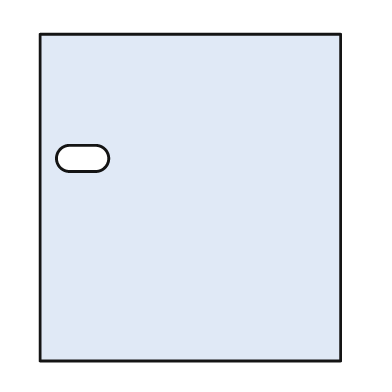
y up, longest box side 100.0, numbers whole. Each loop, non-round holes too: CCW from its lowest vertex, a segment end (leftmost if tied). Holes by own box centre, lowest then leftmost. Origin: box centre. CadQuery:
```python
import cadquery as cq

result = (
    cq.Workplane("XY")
    .moveTo(-46.0, -50.0)
    .lineTo(46.0, -50.0)
    .lineTo(46.0, 50.0)
    .lineTo(-46.0, 50.0)
    .close()
    .moveTo(-37.0, 8.0)
    .lineTo(-29.0, 8.0)
    .threePointArc((-25.0, 12.0), (-29.0, 16.0))
    .lineTo(-37.0, 16.0)
    .threePointArc((-41.0, 12.0), (-37.0, 8.0))
    .close()
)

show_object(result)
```